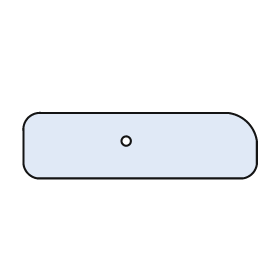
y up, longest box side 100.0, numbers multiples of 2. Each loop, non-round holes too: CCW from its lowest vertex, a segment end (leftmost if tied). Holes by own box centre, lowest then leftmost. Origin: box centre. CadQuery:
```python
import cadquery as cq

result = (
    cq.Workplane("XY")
    .moveTo(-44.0, -14.0)
    .lineTo(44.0, -14.0)
    .threePointArc((48.0, -12.0), (50.0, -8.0))
    .lineTo(50.0, 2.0)
    .threePointArc((46.0, 10.0), (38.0, 14.0))
    .lineTo(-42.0, 14.0)
    .threePointArc((-48.0, 12.0), (-50.0, 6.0))
    .lineTo(-50.0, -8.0)
    .threePointArc((-48.0, -12.0), (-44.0, -14.0))
    .close()
    .moveTo(-6.0, 2.0)
    .circle(2.0)
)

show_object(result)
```